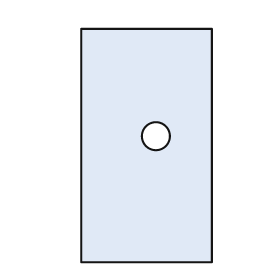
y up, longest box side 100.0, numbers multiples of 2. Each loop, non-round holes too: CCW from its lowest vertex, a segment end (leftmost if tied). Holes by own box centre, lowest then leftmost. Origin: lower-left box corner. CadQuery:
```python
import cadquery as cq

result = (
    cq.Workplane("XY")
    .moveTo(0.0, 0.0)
    .lineTo(56.0, 0.0)
    .lineTo(56.0, 100.0)
    .lineTo(0.0, 100.0)
    .close()
    .moveTo(32.0, 54.0)
    .circle(6.0)
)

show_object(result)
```